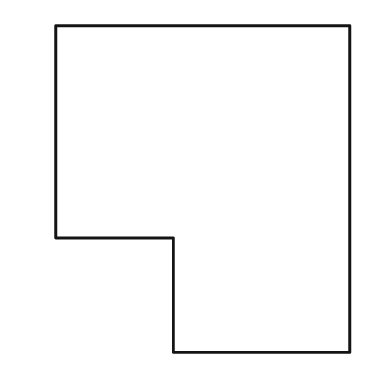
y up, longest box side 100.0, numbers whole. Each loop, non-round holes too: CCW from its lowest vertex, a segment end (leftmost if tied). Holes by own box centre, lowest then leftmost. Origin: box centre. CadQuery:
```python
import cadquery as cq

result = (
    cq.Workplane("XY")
    .moveTo(-9.0, -50.0)
    .lineTo(45.0, -50.0)
    .lineTo(45.0, 50.0)
    .lineTo(-45.0, 50.0)
    .lineTo(-45.0, -15.0)
    .lineTo(-9.0, -15.0)
    .close()
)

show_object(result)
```